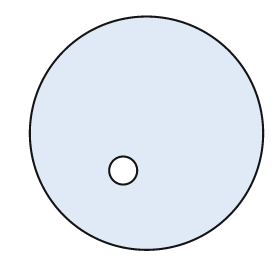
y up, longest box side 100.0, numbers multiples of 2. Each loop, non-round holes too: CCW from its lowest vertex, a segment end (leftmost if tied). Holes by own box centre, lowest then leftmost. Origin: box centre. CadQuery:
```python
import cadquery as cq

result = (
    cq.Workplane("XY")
    .moveTo(0.0, 0.0)
    .circle(50.0)
    .moveTo(-10.0, -16.0)
    .circle(6.0)
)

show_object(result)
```